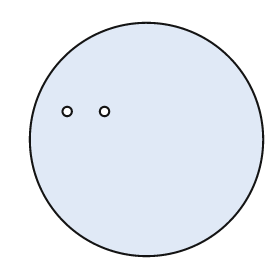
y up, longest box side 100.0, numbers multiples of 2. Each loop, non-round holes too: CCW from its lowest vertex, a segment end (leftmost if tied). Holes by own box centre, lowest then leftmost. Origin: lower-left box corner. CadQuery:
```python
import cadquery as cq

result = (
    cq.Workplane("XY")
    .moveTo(50.0, 50.0)
    .circle(50.0)
    .moveTo(16.0, 62.0)
    .circle(2.0)
    .moveTo(32.0, 62.0)
    .circle(2.0)
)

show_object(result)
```